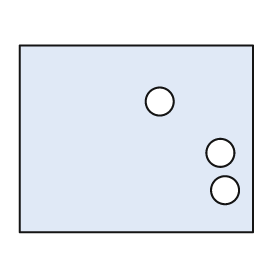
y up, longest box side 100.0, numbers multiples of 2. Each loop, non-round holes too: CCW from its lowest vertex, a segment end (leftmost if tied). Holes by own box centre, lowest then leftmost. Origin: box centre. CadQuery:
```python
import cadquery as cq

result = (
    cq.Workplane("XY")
    .moveTo(-50.0, -40.0)
    .lineTo(50.0, -40.0)
    .lineTo(50.0, 40.0)
    .lineTo(-50.0, 40.0)
    .close()
    .moveTo(38.0, -22.0)
    .circle(6.0)
    .moveTo(36.0, -6.0)
    .circle(6.0)
    .moveTo(10.0, 16.0)
    .circle(6.0)
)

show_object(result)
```